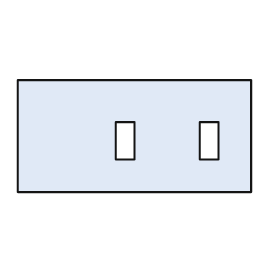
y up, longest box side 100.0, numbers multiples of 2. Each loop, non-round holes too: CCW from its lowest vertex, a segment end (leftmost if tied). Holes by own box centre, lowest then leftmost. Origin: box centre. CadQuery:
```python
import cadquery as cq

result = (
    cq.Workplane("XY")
    .moveTo(-50.0, -24.0)
    .lineTo(50.0, -24.0)
    .lineTo(50.0, 24.0)
    .lineTo(-50.0, 24.0)
    .close()
    .moveTo(-8.0, -10.0)
    .lineTo(0.0, -10.0)
    .lineTo(0.0, 6.0)
    .lineTo(-8.0, 6.0)
    .close()
    .moveTo(28.0, -10.0)
    .lineTo(36.0, -10.0)
    .lineTo(36.0, 6.0)
    .lineTo(28.0, 6.0)
    .close()
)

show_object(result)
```